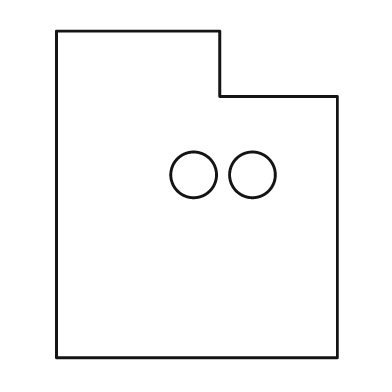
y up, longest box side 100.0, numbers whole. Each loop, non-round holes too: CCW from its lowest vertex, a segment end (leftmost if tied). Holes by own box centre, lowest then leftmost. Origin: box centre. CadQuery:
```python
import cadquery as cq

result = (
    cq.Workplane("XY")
    .moveTo(-43.0, -50.0)
    .lineTo(43.0, -50.0)
    .lineTo(43.0, 30.0)
    .lineTo(7.0, 30.0)
    .lineTo(7.0, 50.0)
    .lineTo(-43.0, 50.0)
    .close()
    .moveTo(-1.0, 6.0)
    .circle(7.0)
    .moveTo(17.0, 6.0)
    .circle(7.0)
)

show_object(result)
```